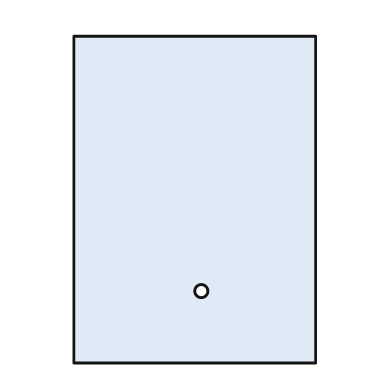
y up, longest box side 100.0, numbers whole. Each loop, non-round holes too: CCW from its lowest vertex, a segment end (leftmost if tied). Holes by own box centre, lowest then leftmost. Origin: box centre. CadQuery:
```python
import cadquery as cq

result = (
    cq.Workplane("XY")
    .moveTo(-37.0, -50.0)
    .lineTo(37.0, -50.0)
    .lineTo(37.0, 50.0)
    .lineTo(-37.0, 50.0)
    .close()
    .moveTo(2.0, -28.0)
    .circle(2.0)
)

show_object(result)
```